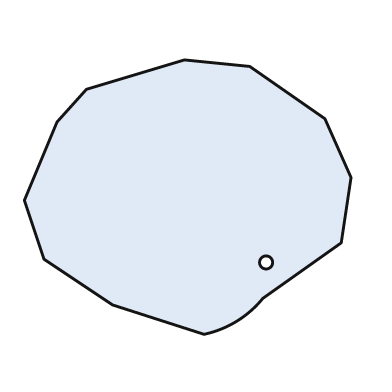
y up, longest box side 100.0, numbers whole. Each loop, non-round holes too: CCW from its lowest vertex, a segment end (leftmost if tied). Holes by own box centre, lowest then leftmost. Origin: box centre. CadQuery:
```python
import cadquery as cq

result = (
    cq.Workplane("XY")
    .moveTo(5.0, -42.0)
    .threePointArc((15.0, -38.0), (23.0, -31.0))
    .lineTo(47.0, -14.0)
    .lineTo(50.0, 6.0)
    .lineTo(42.0, 24.0)
    .lineTo(19.0, 40.0)
    .lineTo(-1.0, 42.0)
    .lineTo(-31.0, 33.0)
    .lineTo(-40.0, 23.0)
    .lineTo(-50.0, -1.0)
    .lineTo(-44.0, -19.0)
    .lineTo(-23.0, -33.0)
    .close()
    .moveTo(24.0, -20.0)
    .circle(2.0)
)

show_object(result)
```